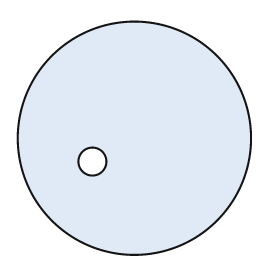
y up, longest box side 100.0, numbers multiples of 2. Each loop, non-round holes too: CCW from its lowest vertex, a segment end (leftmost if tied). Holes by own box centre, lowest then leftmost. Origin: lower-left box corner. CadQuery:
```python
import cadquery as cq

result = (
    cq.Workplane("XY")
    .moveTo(50.0, 50.0)
    .circle(50.0)
    .moveTo(32.0, 40.0)
    .circle(6.0)
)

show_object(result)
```